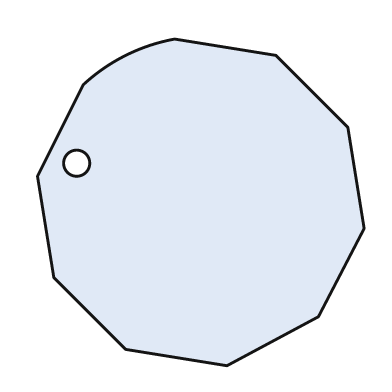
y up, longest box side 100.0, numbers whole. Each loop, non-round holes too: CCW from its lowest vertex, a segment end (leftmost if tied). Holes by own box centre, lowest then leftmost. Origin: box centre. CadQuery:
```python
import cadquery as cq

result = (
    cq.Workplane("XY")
    .moveTo(8.0, -50.0)
    .lineTo(36.0, -35.0)
    .lineTo(50.0, -8.0)
    .lineTo(45.0, 23.0)
    .lineTo(23.0, 45.0)
    .lineTo(-8.0, 50.0)
    .threePointArc((-23.0, 45.0), (-36.0, 36.0))
    .lineTo(-50.0, 8.0)
    .lineTo(-45.0, -23.0)
    .lineTo(-23.0, -45.0)
    .close()
    .moveTo(-38.0, 12.0)
    .circle(4.0)
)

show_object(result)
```